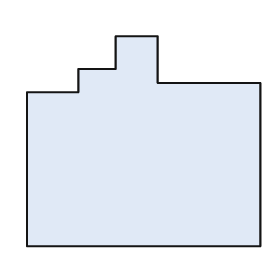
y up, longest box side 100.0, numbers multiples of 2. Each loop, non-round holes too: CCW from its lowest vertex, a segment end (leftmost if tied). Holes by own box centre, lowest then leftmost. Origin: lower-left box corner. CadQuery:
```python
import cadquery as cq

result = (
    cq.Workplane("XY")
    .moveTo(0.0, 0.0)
    .lineTo(100.0, 0.0)
    .lineTo(100.0, 70.0)
    .lineTo(56.0, 70.0)
    .lineTo(56.0, 90.0)
    .lineTo(38.0, 90.0)
    .lineTo(38.0, 76.0)
    .lineTo(22.0, 76.0)
    .lineTo(22.0, 66.0)
    .lineTo(0.0, 66.0)
    .close()
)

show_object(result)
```